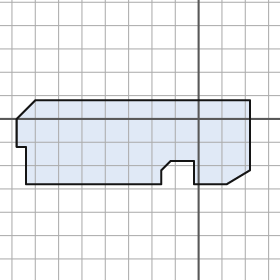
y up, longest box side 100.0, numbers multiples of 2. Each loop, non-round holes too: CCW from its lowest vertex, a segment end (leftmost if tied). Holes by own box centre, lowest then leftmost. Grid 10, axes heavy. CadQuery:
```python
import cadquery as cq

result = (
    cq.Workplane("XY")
    .moveTo(-74.0, -28.0)
    .lineTo(-16.0, -28.0)
    .lineTo(-16.0, -22.0)
    .lineTo(-12.0, -18.0)
    .lineTo(-2.0, -18.0)
    .lineTo(-2.0, -28.0)
    .lineTo(12.0, -28.0)
    .lineTo(22.0, -22.0)
    .lineTo(22.0, 8.0)
    .lineTo(-70.0, 8.0)
    .lineTo(-78.0, 0.0)
    .lineTo(-78.0, -12.0)
    .lineTo(-74.0, -12.0)
    .close()
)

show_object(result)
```